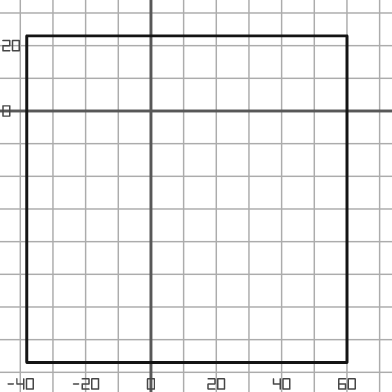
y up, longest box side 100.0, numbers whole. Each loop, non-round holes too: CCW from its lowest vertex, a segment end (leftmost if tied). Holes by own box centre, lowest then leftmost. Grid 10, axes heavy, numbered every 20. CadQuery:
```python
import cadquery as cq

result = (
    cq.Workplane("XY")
    .moveTo(-38.0, -77.0)
    .lineTo(60.0, -77.0)
    .lineTo(60.0, 23.0)
    .lineTo(-38.0, 23.0)
    .close()
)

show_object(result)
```